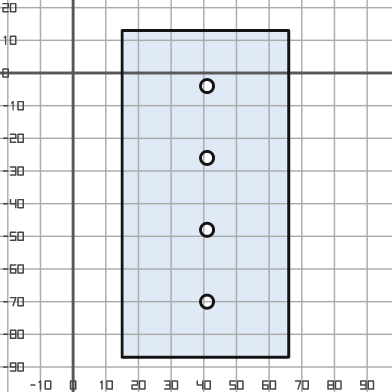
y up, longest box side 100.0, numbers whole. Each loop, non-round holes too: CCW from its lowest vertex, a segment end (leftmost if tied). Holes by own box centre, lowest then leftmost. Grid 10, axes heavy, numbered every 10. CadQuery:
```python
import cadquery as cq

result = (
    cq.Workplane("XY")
    .moveTo(15.0, -87.0)
    .lineTo(66.0, -87.0)
    .lineTo(66.0, 13.0)
    .lineTo(15.0, 13.0)
    .close()
    .moveTo(41.0, -70.0)
    .circle(2.0)
    .moveTo(41.0, -48.0)
    .circle(2.0)
    .moveTo(41.0, -26.0)
    .circle(2.0)
    .moveTo(41.0, -4.0)
    .circle(2.0)
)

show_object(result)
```